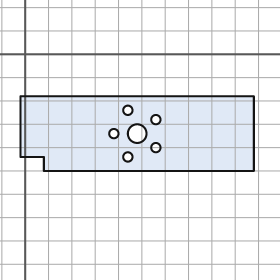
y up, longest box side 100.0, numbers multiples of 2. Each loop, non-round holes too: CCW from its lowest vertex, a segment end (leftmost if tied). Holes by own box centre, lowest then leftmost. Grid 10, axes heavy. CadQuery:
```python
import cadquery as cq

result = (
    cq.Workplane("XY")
    .moveTo(8.0, -50.0)
    .lineTo(98.0, -50.0)
    .lineTo(98.0, -18.0)
    .lineTo(-2.0, -18.0)
    .lineTo(-2.0, -44.0)
    .lineTo(8.0, -44.0)
    .close()
    .moveTo(44.0, -44.0)
    .circle(2.0)
    .moveTo(56.0, -40.0)
    .circle(2.0)
    .moveTo(38.0, -34.0)
    .circle(2.0)
    .moveTo(48.0, -34.0)
    .circle(4.0)
    .moveTo(56.0, -28.0)
    .circle(2.0)
    .moveTo(44.0, -24.0)
    .circle(2.0)
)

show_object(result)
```